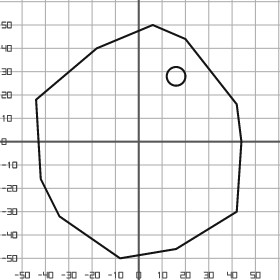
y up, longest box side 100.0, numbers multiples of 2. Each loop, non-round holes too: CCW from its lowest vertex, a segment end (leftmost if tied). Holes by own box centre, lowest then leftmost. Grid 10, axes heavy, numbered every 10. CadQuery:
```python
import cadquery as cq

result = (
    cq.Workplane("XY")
    .moveTo(-8.0, -50.0)
    .lineTo(16.0, -46.0)
    .lineTo(42.0, -30.0)
    .lineTo(44.0, 0.0)
    .lineTo(42.0, 16.0)
    .lineTo(20.0, 44.0)
    .lineTo(6.0, 50.0)
    .lineTo(-18.0, 40.0)
    .lineTo(-44.0, 18.0)
    .lineTo(-42.0, -16.0)
    .lineTo(-34.0, -32.0)
    .close()
    .moveTo(16.0, 28.0)
    .circle(4.0)
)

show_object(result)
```